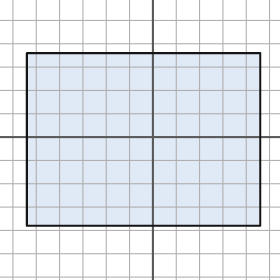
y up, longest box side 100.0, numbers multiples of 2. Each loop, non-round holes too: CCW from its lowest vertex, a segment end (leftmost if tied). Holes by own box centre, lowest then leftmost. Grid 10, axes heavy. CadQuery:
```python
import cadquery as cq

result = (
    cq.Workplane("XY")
    .moveTo(-54.0, -38.0)
    .lineTo(46.0, -38.0)
    .lineTo(46.0, 36.0)
    .lineTo(-54.0, 36.0)
    .close()
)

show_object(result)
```